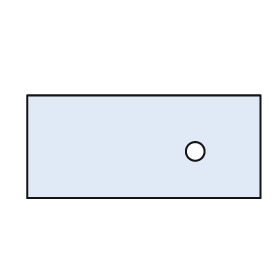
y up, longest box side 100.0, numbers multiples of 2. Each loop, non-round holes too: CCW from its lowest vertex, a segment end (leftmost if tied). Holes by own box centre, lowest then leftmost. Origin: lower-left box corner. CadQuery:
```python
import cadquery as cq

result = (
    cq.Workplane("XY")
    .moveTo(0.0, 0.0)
    .lineTo(100.0, 0.0)
    .lineTo(100.0, 44.0)
    .lineTo(0.0, 44.0)
    .close()
    .moveTo(72.0, 20.0)
    .circle(4.0)
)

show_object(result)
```